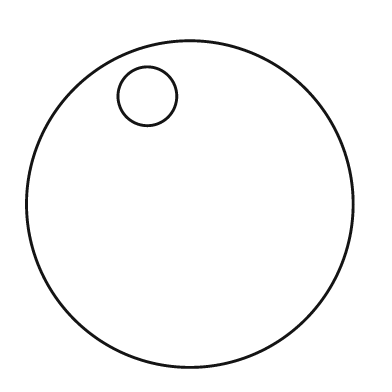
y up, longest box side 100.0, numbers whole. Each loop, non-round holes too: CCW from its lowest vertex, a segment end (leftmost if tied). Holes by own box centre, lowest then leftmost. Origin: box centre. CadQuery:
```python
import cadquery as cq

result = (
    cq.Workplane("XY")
    .moveTo(0.0, 0.0)
    .circle(50.0)
    .moveTo(-13.0, 33.0)
    .circle(9.0)
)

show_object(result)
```